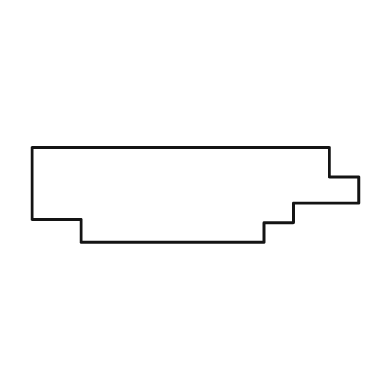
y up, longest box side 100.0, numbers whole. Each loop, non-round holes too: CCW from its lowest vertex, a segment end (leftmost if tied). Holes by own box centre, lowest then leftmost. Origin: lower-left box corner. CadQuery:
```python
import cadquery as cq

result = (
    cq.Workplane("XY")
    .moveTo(15.0, 0.0)
    .lineTo(71.0, 0.0)
    .lineTo(71.0, 6.0)
    .lineTo(80.0, 6.0)
    .lineTo(80.0, 12.0)
    .lineTo(100.0, 12.0)
    .lineTo(100.0, 20.0)
    .lineTo(91.0, 20.0)
    .lineTo(91.0, 29.0)
    .lineTo(0.0, 29.0)
    .lineTo(0.0, 7.0)
    .lineTo(15.0, 7.0)
    .close()
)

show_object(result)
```